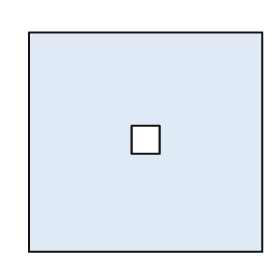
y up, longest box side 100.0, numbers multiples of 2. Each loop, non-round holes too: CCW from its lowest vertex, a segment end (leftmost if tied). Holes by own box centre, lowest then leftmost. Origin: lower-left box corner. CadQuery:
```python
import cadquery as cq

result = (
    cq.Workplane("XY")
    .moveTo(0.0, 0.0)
    .lineTo(100.0, 0.0)
    .lineTo(100.0, 94.0)
    .lineTo(0.0, 94.0)
    .close()
    .moveTo(44.0, 42.0)
    .lineTo(56.0, 42.0)
    .lineTo(56.0, 54.0)
    .lineTo(44.0, 54.0)
    .close()
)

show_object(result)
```